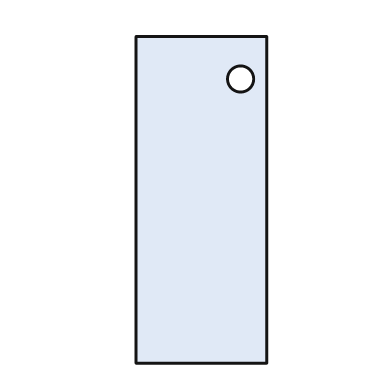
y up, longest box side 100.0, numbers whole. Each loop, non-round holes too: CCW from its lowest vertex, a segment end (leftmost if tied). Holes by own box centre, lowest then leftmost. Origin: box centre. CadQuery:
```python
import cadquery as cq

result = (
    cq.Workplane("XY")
    .moveTo(-20.0, -50.0)
    .lineTo(20.0, -50.0)
    .lineTo(20.0, 50.0)
    .lineTo(-20.0, 50.0)
    .close()
    .moveTo(12.0, 37.0)
    .circle(4.0)
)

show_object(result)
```